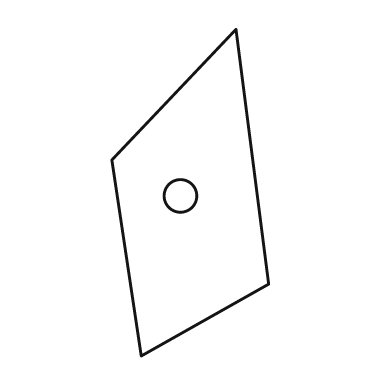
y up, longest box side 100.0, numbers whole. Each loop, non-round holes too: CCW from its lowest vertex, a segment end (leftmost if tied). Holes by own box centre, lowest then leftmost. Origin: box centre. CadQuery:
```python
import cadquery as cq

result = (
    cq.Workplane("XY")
    .moveTo(-15.0, -50.0)
    .lineTo(24.0, -28.0)
    .lineTo(14.0, 50.0)
    .lineTo(-24.0, 10.0)
    .close()
    .moveTo(-3.0, -1.0)
    .circle(5.0)
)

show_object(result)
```